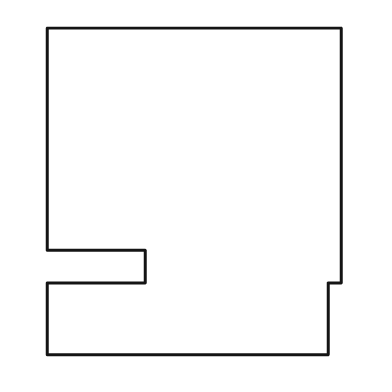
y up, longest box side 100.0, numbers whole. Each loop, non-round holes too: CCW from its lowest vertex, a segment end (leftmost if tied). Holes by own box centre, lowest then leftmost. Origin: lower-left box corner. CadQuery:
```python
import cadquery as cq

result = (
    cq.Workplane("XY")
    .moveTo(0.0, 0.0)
    .lineTo(86.0, 0.0)
    .lineTo(86.0, 22.0)
    .lineTo(90.0, 22.0)
    .lineTo(90.0, 100.0)
    .lineTo(0.0, 100.0)
    .lineTo(0.0, 32.0)
    .lineTo(30.0, 32.0)
    .lineTo(30.0, 22.0)
    .lineTo(0.0, 22.0)
    .close()
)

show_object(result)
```